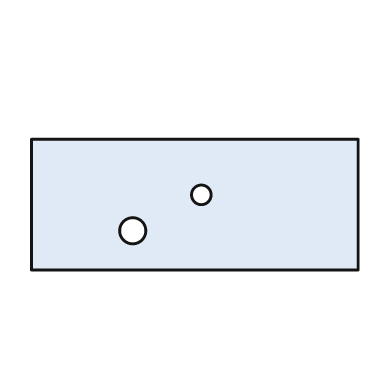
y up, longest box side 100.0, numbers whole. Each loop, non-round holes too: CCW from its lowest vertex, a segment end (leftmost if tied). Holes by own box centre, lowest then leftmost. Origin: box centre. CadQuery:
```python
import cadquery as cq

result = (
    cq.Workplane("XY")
    .moveTo(-50.0, -20.0)
    .lineTo(50.0, -20.0)
    .lineTo(50.0, 20.0)
    .lineTo(-50.0, 20.0)
    .close()
    .moveTo(-19.0, -8.0)
    .circle(4.0)
    .moveTo(2.0, 3.0)
    .circle(3.0)
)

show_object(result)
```